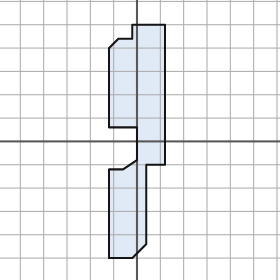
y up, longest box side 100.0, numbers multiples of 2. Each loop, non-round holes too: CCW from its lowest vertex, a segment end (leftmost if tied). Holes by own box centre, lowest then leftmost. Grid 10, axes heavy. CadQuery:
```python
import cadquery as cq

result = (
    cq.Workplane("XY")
    .moveTo(-12.0, -50.0)
    .lineTo(-2.0, -50.0)
    .lineTo(4.0, -44.0)
    .lineTo(4.0, -10.0)
    .lineTo(12.0, -10.0)
    .lineTo(12.0, 50.0)
    .lineTo(-2.0, 50.0)
    .lineTo(-2.0, 44.0)
    .lineTo(-8.0, 44.0)
    .lineTo(-12.0, 40.0)
    .lineTo(-12.0, 6.0)
    .lineTo(0.0, 6.0)
    .lineTo(0.0, -8.0)
    .lineTo(-6.0, -12.0)
    .lineTo(-12.0, -12.0)
    .close()
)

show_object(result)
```